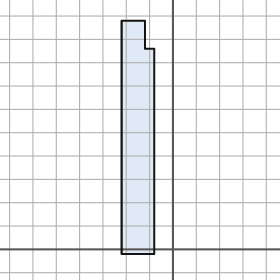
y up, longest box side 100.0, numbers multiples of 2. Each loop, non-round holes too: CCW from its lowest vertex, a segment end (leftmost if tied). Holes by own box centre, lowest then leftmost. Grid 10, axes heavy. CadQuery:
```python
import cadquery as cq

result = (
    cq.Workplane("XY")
    .moveTo(-22.0, -2.0)
    .lineTo(-8.0, -2.0)
    .lineTo(-8.0, 86.0)
    .lineTo(-12.0, 86.0)
    .lineTo(-12.0, 98.0)
    .lineTo(-22.0, 98.0)
    .close()
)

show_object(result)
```